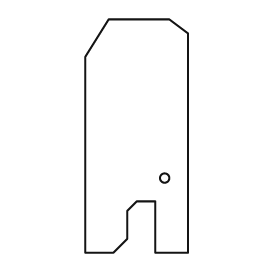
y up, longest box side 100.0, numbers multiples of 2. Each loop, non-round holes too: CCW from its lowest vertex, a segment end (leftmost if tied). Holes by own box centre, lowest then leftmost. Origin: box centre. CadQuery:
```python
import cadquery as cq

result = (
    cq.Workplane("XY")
    .moveTo(-22.0, -50.0)
    .lineTo(-10.0, -50.0)
    .lineTo(-4.0, -44.0)
    .lineTo(-4.0, -32.0)
    .lineTo(0.0, -28.0)
    .lineTo(8.0, -28.0)
    .lineTo(8.0, -50.0)
    .lineTo(22.0, -50.0)
    .lineTo(22.0, 44.0)
    .lineTo(14.0, 50.0)
    .lineTo(-12.0, 50.0)
    .lineTo(-22.0, 34.0)
    .close()
    .moveTo(12.0, -18.0)
    .circle(2.0)
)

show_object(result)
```